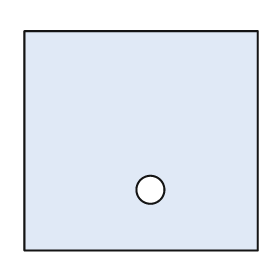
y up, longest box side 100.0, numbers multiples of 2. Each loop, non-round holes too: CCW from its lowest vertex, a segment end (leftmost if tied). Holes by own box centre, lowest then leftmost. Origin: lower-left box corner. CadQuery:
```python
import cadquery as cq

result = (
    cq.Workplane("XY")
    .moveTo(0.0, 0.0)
    .lineTo(100.0, 0.0)
    .lineTo(100.0, 94.0)
    .lineTo(0.0, 94.0)
    .close()
    .moveTo(54.0, 26.0)
    .circle(6.0)
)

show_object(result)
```